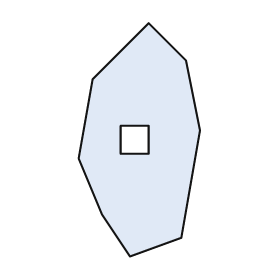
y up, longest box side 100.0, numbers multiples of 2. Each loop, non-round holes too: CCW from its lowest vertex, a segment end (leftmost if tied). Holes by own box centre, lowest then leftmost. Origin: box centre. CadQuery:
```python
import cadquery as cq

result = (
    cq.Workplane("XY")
    .moveTo(-4.0, -50.0)
    .lineTo(18.0, -42.0)
    .lineTo(26.0, 4.0)
    .lineTo(20.0, 34.0)
    .lineTo(4.0, 50.0)
    .lineTo(-20.0, 26.0)
    .lineTo(-26.0, -8.0)
    .lineTo(-16.0, -32.0)
    .close()
    .moveTo(-8.0, -6.0)
    .lineTo(4.0, -6.0)
    .lineTo(4.0, 6.0)
    .lineTo(-8.0, 6.0)
    .close()
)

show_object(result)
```